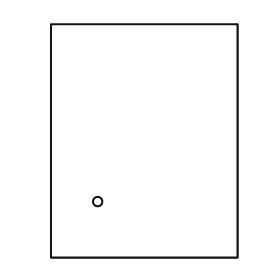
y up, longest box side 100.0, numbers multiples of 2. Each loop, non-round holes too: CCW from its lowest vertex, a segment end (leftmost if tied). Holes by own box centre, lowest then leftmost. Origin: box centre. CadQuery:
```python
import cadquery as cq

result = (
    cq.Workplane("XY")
    .moveTo(-40.0, -50.0)
    .lineTo(40.0, -50.0)
    .lineTo(40.0, 50.0)
    .lineTo(-40.0, 50.0)
    .close()
    .moveTo(-20.0, -26.0)
    .circle(2.0)
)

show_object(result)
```